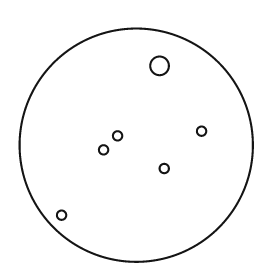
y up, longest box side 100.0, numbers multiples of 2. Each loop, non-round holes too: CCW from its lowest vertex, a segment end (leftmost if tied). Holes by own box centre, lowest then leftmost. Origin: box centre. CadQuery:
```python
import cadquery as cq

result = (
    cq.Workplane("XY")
    .moveTo(0.0, 0.0)
    .circle(50.0)
    .moveTo(-32.0, -30.0)
    .circle(2.0)
    .moveTo(12.0, -10.0)
    .circle(2.0)
    .moveTo(-14.0, -2.0)
    .circle(2.0)
    .moveTo(-8.0, 4.0)
    .circle(2.0)
    .moveTo(28.0, 6.0)
    .circle(2.0)
    .moveTo(10.0, 34.0)
    .circle(4.0)
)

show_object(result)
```